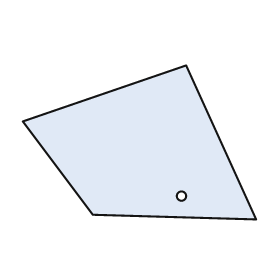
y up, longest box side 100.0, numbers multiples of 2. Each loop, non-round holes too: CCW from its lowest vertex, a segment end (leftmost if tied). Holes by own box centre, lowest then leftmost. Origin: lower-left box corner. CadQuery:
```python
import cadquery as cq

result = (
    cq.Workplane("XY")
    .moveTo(100.0, 0.0)
    .lineTo(70.0, 66.0)
    .lineTo(0.0, 42.0)
    .lineTo(30.0, 2.0)
    .close()
    .moveTo(68.0, 10.0)
    .circle(2.0)
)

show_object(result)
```